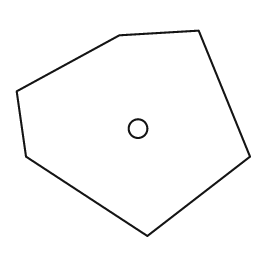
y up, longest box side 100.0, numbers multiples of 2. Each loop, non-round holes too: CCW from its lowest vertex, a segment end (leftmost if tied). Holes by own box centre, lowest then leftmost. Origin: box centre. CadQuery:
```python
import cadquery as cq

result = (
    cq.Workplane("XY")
    .moveTo(6.0, -44.0)
    .lineTo(50.0, -10.0)
    .lineTo(28.0, 44.0)
    .lineTo(-6.0, 42.0)
    .lineTo(-50.0, 18.0)
    .lineTo(-46.0, -10.0)
    .close()
    .moveTo(2.0, 2.0)
    .circle(4.0)
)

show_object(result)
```